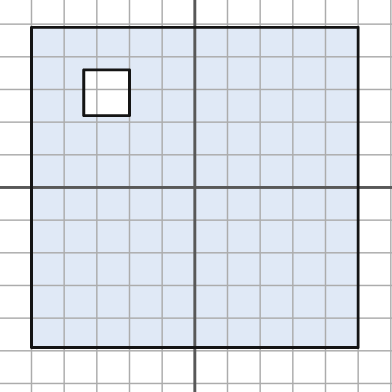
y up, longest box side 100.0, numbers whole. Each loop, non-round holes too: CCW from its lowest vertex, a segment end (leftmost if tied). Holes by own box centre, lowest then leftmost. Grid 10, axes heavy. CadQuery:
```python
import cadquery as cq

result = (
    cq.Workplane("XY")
    .moveTo(-50.0, -49.0)
    .lineTo(50.0, -49.0)
    .lineTo(50.0, 49.0)
    .lineTo(-50.0, 49.0)
    .close()
    .moveTo(-34.0, 22.0)
    .lineTo(-20.0, 22.0)
    .lineTo(-20.0, 36.0)
    .lineTo(-34.0, 36.0)
    .close()
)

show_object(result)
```